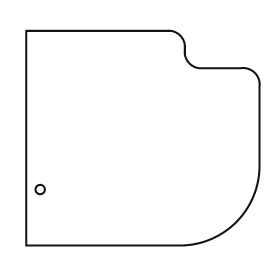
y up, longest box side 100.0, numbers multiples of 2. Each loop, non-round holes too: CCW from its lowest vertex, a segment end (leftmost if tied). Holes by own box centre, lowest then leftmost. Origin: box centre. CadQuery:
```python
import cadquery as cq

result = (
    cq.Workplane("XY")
    .moveTo(-50.0, -46.0)
    .lineTo(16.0, -46.0)
    .threePointArc((40.0, -36.0), (50.0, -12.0))
    .lineTo(50.0, 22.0)
    .threePointArc((48.0, 28.0), (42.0, 30.0))
    .lineTo(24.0, 30.0)
    .threePointArc((20.0, 32.0), (18.0, 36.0))
    .lineTo(18.0, 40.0)
    .threePointArc((16.0, 44.0), (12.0, 46.0))
    .lineTo(-50.0, 46.0)
    .close()
    .moveTo(-44.0, -22.0)
    .circle(2.0)
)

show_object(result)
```